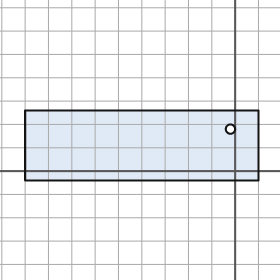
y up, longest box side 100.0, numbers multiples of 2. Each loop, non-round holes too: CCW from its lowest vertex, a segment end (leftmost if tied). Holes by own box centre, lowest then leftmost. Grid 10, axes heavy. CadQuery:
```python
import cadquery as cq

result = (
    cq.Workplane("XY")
    .moveTo(-90.0, -4.0)
    .lineTo(10.0, -4.0)
    .lineTo(10.0, 26.0)
    .lineTo(-90.0, 26.0)
    .close()
    .moveTo(-2.0, 18.0)
    .circle(2.0)
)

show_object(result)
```